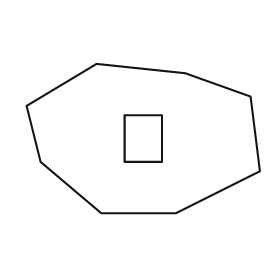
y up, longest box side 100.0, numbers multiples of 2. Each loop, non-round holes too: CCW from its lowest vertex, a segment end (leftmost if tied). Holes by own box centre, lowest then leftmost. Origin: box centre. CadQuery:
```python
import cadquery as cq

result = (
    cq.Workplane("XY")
    .moveTo(-18.0, -32.0)
    .lineTo(14.0, -32.0)
    .lineTo(50.0, -14.0)
    .lineTo(46.0, 18.0)
    .lineTo(18.0, 28.0)
    .lineTo(-20.0, 32.0)
    .lineTo(-50.0, 14.0)
    .lineTo(-44.0, -10.0)
    .close()
    .moveTo(-8.0, -10.0)
    .lineTo(8.0, -10.0)
    .lineTo(8.0, 10.0)
    .lineTo(-8.0, 10.0)
    .close()
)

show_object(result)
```